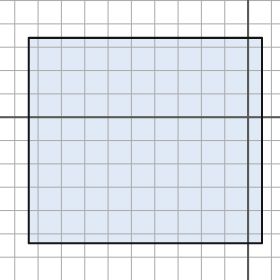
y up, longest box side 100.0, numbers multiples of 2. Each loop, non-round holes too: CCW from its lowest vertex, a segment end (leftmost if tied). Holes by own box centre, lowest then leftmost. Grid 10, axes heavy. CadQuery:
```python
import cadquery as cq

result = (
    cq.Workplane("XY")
    .moveTo(-94.0, -54.0)
    .lineTo(6.0, -54.0)
    .lineTo(6.0, 34.0)
    .lineTo(-94.0, 34.0)
    .close()
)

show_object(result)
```